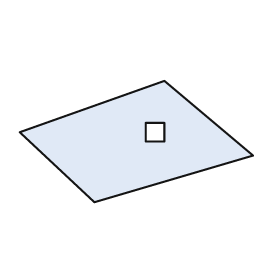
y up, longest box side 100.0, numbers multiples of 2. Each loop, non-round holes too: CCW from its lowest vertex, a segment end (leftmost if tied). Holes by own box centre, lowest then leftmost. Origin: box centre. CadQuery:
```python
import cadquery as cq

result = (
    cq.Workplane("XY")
    .moveTo(-18.0, -26.0)
    .lineTo(50.0, -6.0)
    .lineTo(12.0, 26.0)
    .lineTo(-50.0, 4.0)
    .close()
    .moveTo(4.0, 0.0)
    .lineTo(12.0, 0.0)
    .lineTo(12.0, 8.0)
    .lineTo(4.0, 8.0)
    .close()
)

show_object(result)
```